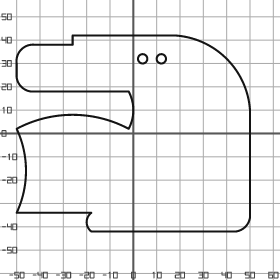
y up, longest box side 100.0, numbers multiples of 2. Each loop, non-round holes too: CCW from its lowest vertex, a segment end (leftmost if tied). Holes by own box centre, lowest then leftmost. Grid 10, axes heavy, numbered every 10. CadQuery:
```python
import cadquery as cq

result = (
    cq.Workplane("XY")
    .moveTo(-18.0, -42.0)
    .lineTo(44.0, -42.0)
    .threePointArc((48.0, -40.0), (50.0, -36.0))
    .lineTo(50.0, 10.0)
    .threePointArc((40.0, 32.0), (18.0, 42.0))
    .lineTo(-26.0, 42.0)
    .lineTo(-26.0, 38.0)
    .lineTo(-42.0, 38.0)
    .threePointArc((-48.0, 36.0), (-50.0, 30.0))
    .lineTo(-50.0, 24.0)
    .threePointArc((-48.0, 20.0), (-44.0, 18.0))
    .lineTo(-2.0, 18.0)
    .threePointArc((0.0, 10.0), (-2.0, 2.0))
    .threePointArc((-26.0, 8.0), (-50.0, 2.0))
    .threePointArc((-46.0, -16.0), (-50.0, -34.0))
    .lineTo(-18.0, -34.0)
    .threePointArc((-20.0, -38.0), (-18.0, -42.0))
    .close()
    .moveTo(4.0, 32.0)
    .circle(2.0)
    .moveTo(12.0, 32.0)
    .circle(2.0)
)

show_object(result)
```